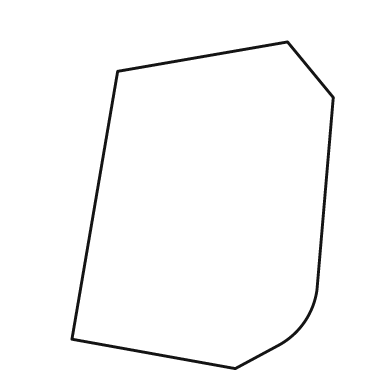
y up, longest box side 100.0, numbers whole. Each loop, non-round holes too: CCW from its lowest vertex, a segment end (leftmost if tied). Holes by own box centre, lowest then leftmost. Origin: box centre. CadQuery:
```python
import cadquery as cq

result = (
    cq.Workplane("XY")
    .moveTo(10.0, -50.0)
    .lineTo(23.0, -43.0)
    .threePointArc((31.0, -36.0), (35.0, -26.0))
    .lineTo(40.0, 33.0)
    .lineTo(26.0, 50.0)
    .lineTo(-26.0, 41.0)
    .lineTo(-40.0, -41.0)
    .close()
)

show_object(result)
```